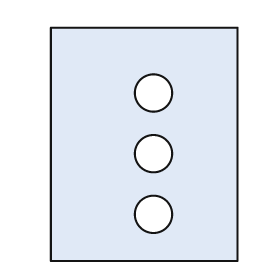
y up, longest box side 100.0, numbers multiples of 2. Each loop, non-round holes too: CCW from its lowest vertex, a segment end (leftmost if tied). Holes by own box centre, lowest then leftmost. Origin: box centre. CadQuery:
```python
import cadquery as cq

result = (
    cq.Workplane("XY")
    .moveTo(-40.0, -50.0)
    .lineTo(40.0, -50.0)
    .lineTo(40.0, 50.0)
    .lineTo(-40.0, 50.0)
    .close()
    .moveTo(4.0, -30.0)
    .circle(8.0)
    .moveTo(4.0, -4.0)
    .circle(8.0)
    .moveTo(4.0, 22.0)
    .circle(8.0)
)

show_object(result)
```